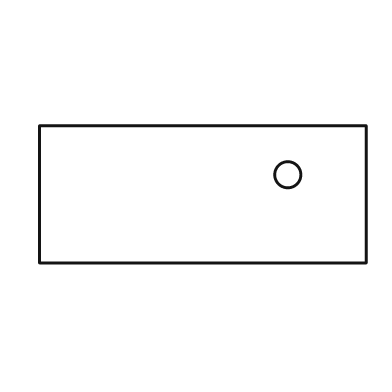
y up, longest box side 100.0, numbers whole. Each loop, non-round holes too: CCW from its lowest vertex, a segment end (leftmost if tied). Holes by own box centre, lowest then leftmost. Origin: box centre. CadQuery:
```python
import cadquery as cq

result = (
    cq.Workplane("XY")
    .moveTo(-50.0, -21.0)
    .lineTo(50.0, -21.0)
    .lineTo(50.0, 21.0)
    .lineTo(-50.0, 21.0)
    .close()
    .moveTo(26.0, 6.0)
    .circle(4.0)
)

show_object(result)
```